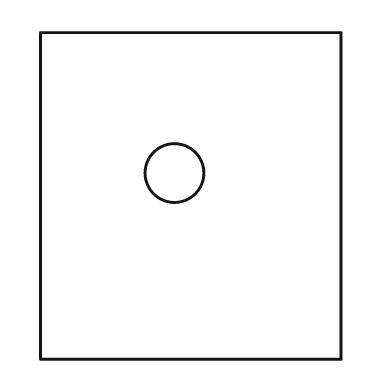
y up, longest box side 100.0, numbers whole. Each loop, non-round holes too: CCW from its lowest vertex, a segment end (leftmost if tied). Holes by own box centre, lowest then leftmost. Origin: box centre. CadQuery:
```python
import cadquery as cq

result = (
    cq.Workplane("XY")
    .moveTo(-46.0, -50.0)
    .lineTo(46.0, -50.0)
    .lineTo(46.0, 50.0)
    .lineTo(-46.0, 50.0)
    .close()
    .moveTo(-5.0, 7.0)
    .circle(9.0)
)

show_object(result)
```